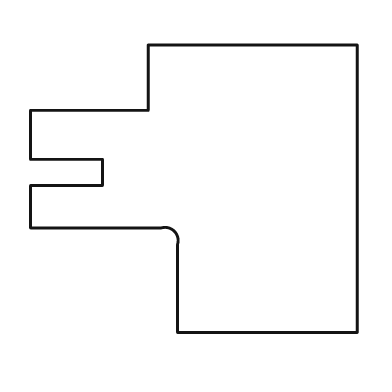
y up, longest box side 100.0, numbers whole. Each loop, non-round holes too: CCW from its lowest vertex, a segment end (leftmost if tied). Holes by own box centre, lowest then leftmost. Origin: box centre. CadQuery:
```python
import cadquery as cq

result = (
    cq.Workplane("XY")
    .moveTo(-5.0, -44.0)
    .lineTo(50.0, -44.0)
    .lineTo(50.0, 44.0)
    .lineTo(-14.0, 44.0)
    .lineTo(-14.0, 24.0)
    .lineTo(-50.0, 24.0)
    .lineTo(-50.0, 9.0)
    .lineTo(-28.0, 9.0)
    .lineTo(-28.0, 1.0)
    .lineTo(-50.0, 1.0)
    .lineTo(-50.0, -12.0)
    .lineTo(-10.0, -12.0)
    .threePointArc((-6.0, -13.0), (-5.0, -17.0))
    .close()
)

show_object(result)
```